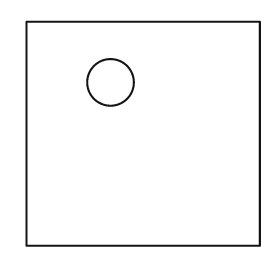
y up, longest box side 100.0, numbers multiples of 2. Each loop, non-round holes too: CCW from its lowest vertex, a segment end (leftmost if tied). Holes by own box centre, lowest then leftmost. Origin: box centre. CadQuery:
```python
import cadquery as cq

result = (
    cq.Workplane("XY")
    .moveTo(-50.0, -48.0)
    .lineTo(50.0, -48.0)
    .lineTo(50.0, 48.0)
    .lineTo(-50.0, 48.0)
    .close()
    .moveTo(-14.0, 22.0)
    .circle(10.0)
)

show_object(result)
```